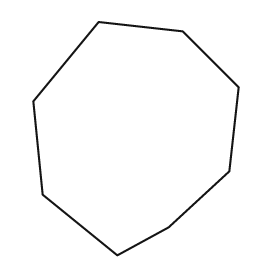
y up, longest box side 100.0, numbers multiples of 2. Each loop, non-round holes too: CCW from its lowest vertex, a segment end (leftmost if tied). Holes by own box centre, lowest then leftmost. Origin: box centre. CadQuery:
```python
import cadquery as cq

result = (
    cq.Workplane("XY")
    .moveTo(-8.0, -50.0)
    .lineTo(14.0, -38.0)
    .lineTo(40.0, -14.0)
    .lineTo(44.0, 22.0)
    .lineTo(20.0, 46.0)
    .lineTo(-16.0, 50.0)
    .lineTo(-44.0, 16.0)
    .lineTo(-40.0, -24.0)
    .close()
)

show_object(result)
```